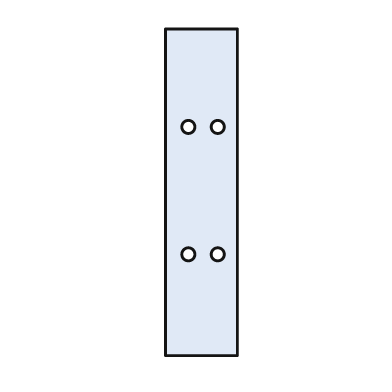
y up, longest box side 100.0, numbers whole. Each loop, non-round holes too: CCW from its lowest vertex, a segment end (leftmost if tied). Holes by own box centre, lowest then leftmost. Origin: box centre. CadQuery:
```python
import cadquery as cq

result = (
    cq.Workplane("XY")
    .moveTo(-11.0, -50.0)
    .lineTo(11.0, -50.0)
    .lineTo(11.0, 50.0)
    .lineTo(-11.0, 50.0)
    .close()
    .moveTo(-4.0, -19.0)
    .circle(2.0)
    .moveTo(5.0, -19.0)
    .circle(2.0)
    .moveTo(-4.0, 20.0)
    .circle(2.0)
    .moveTo(5.0, 20.0)
    .circle(2.0)
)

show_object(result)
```